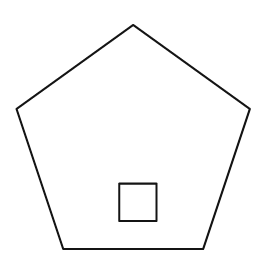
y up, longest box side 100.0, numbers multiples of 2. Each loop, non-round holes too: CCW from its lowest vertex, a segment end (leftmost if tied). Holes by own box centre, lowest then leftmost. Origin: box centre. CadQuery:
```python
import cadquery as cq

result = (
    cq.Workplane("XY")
    .moveTo(-30.0, -48.0)
    .lineTo(30.0, -48.0)
    .lineTo(50.0, 12.0)
    .lineTo(0.0, 48.0)
    .lineTo(-50.0, 12.0)
    .close()
    .moveTo(-6.0, -36.0)
    .lineTo(10.0, -36.0)
    .lineTo(10.0, -20.0)
    .lineTo(-6.0, -20.0)
    .close()
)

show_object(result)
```